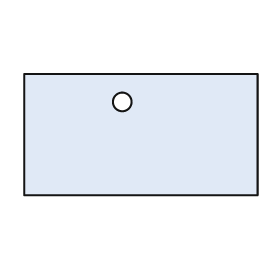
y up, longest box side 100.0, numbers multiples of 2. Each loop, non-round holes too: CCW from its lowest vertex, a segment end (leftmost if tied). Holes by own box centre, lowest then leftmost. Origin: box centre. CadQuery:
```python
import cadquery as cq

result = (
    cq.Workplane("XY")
    .moveTo(-50.0, -26.0)
    .lineTo(50.0, -26.0)
    .lineTo(50.0, 26.0)
    .lineTo(-50.0, 26.0)
    .close()
    .moveTo(-8.0, 14.0)
    .circle(4.0)
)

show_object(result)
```